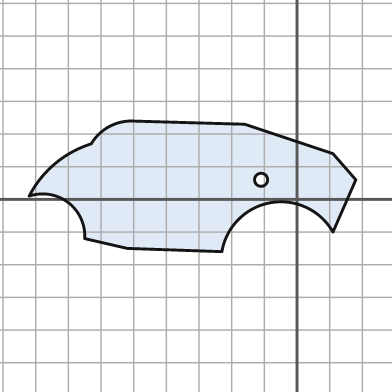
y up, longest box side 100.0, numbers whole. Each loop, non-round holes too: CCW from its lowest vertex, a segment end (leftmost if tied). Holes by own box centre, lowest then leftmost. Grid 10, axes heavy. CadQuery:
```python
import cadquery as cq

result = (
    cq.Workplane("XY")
    .moveTo(-23.0, -16.0)
    .threePointArc((-8.0, -1.0), (11.0, -10.0))
    .lineTo(18.0, 6.0)
    .lineTo(11.0, 14.0)
    .lineTo(-16.0, 23.0)
    .lineTo(-51.0, 24.0)
    .threePointArc((-58.0, 22.0), (-63.0, 17.0))
    .threePointArc((-74.0, 11.0), (-82.0, 1.0))
    .threePointArc((-70.0, -1.0), (-65.0, -12.0))
    .lineTo(-52.0, -15.0)
    .close()
    .moveTo(-11.0, 6.0)
    .circle(2.0)
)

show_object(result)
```